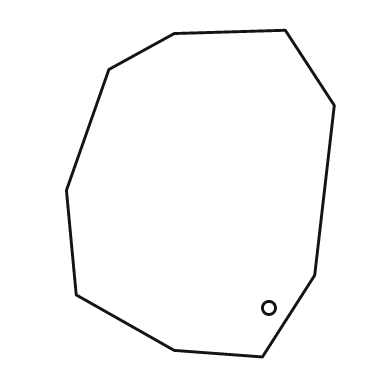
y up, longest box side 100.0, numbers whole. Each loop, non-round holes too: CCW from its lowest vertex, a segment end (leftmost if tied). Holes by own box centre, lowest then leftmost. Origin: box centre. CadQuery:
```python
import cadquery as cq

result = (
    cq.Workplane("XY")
    .moveTo(19.0, -50.0)
    .lineTo(35.0, -25.0)
    .lineTo(41.0, 27.0)
    .lineTo(26.0, 50.0)
    .lineTo(-8.0, 49.0)
    .lineTo(-28.0, 38.0)
    .lineTo(-41.0, 1.0)
    .lineTo(-38.0, -31.0)
    .lineTo(-8.0, -48.0)
    .close()
    .moveTo(21.0, -35.0)
    .circle(2.0)
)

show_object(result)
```